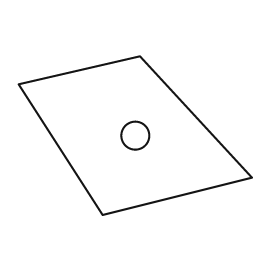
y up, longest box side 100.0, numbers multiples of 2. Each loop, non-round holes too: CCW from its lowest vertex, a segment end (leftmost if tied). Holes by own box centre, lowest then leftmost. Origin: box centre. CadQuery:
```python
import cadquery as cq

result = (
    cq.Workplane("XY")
    .moveTo(-14.0, -34.0)
    .lineTo(50.0, -18.0)
    .lineTo(2.0, 34.0)
    .lineTo(-50.0, 22.0)
    .close()
    .moveTo(0.0, 0.0)
    .circle(6.0)
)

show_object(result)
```